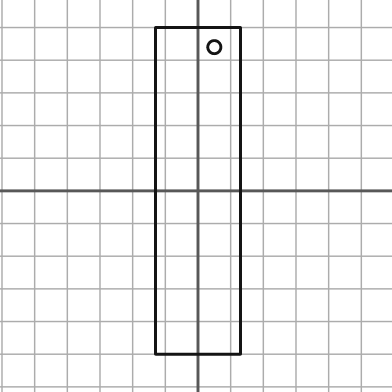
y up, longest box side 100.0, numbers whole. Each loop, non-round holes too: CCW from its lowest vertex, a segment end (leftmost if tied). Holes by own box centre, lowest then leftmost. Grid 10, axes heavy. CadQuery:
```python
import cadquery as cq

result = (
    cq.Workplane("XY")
    .moveTo(-13.0, -50.0)
    .lineTo(13.0, -50.0)
    .lineTo(13.0, 50.0)
    .lineTo(-13.0, 50.0)
    .close()
    .moveTo(5.0, 44.0)
    .circle(2.0)
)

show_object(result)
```